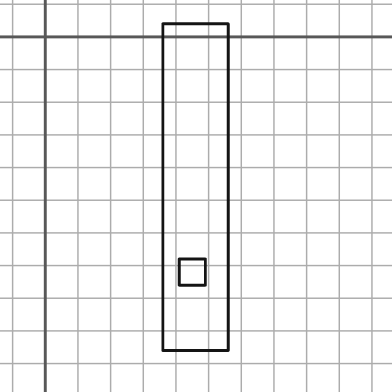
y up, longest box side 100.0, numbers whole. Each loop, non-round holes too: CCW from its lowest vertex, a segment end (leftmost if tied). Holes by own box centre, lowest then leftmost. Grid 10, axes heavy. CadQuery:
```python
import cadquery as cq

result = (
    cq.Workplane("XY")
    .moveTo(36.0, -96.0)
    .lineTo(56.0, -96.0)
    .lineTo(56.0, 4.0)
    .lineTo(36.0, 4.0)
    .close()
    .moveTo(41.0, -76.0)
    .lineTo(49.0, -76.0)
    .lineTo(49.0, -68.0)
    .lineTo(41.0, -68.0)
    .close()
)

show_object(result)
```